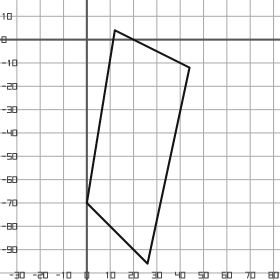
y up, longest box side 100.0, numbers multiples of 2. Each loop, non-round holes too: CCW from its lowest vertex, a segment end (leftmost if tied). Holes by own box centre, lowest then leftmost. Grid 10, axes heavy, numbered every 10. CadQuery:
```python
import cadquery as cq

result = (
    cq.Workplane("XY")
    .moveTo(26.0, -96.0)
    .lineTo(44.0, -12.0)
    .lineTo(12.0, 4.0)
    .lineTo(0.0, -70.0)
    .close()
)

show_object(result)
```